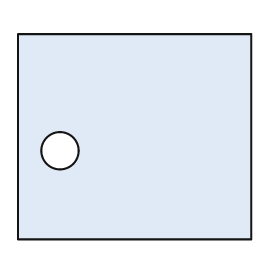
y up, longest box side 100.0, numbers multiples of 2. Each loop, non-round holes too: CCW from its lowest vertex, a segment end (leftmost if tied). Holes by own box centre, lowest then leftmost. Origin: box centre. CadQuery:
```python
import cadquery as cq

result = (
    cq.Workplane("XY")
    .moveTo(-50.0, -44.0)
    .lineTo(50.0, -44.0)
    .lineTo(50.0, 44.0)
    .lineTo(-50.0, 44.0)
    .close()
    .moveTo(-32.0, -6.0)
    .circle(8.0)
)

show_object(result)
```